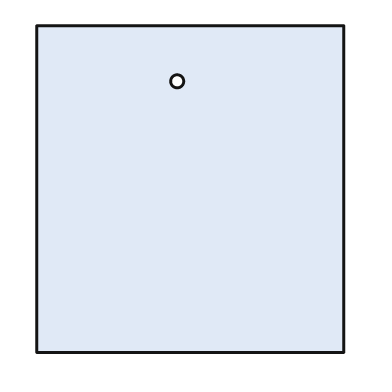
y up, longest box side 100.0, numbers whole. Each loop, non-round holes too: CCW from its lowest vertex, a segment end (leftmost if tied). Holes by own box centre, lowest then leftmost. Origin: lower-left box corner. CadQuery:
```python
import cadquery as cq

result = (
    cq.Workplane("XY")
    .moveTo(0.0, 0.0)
    .lineTo(94.0, 0.0)
    .lineTo(94.0, 100.0)
    .lineTo(0.0, 100.0)
    .close()
    .moveTo(43.0, 83.0)
    .circle(2.0)
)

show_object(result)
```